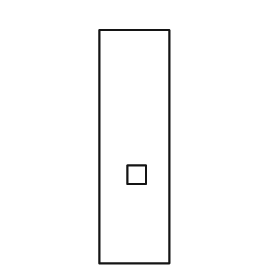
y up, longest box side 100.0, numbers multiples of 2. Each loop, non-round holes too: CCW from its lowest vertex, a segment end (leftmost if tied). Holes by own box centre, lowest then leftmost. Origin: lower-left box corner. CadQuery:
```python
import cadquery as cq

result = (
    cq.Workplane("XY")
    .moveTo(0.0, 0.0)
    .lineTo(30.0, 0.0)
    .lineTo(30.0, 100.0)
    .lineTo(0.0, 100.0)
    .close()
    .moveTo(12.0, 34.0)
    .lineTo(20.0, 34.0)
    .lineTo(20.0, 42.0)
    .lineTo(12.0, 42.0)
    .close()
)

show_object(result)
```